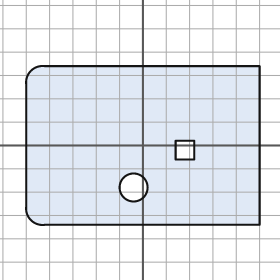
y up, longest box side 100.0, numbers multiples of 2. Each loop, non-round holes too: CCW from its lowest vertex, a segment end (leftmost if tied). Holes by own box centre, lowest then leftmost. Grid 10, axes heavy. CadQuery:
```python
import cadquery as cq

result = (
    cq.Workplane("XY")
    .moveTo(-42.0, -34.0)
    .lineTo(50.0, -34.0)
    .lineTo(50.0, 34.0)
    .lineTo(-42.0, 34.0)
    .threePointArc((-48.0, 32.0), (-50.0, 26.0))
    .lineTo(-50.0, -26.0)
    .threePointArc((-48.0, -32.0), (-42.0, -34.0))
    .close()
    .moveTo(-4.0, -18.0)
    .circle(6.0)
    .moveTo(14.0, -6.0)
    .lineTo(22.0, -6.0)
    .lineTo(22.0, 2.0)
    .lineTo(14.0, 2.0)
    .close()
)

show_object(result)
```